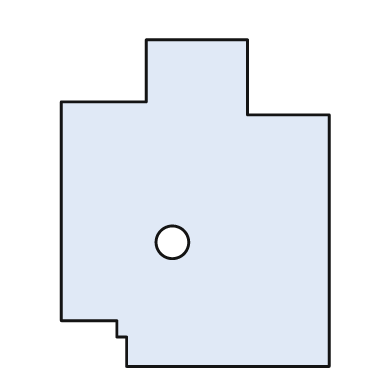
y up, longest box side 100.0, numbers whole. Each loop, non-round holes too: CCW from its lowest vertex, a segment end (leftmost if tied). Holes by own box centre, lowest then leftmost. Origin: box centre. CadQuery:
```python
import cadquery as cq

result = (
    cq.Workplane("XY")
    .moveTo(-21.0, -50.0)
    .lineTo(41.0, -50.0)
    .lineTo(41.0, 27.0)
    .lineTo(16.0, 27.0)
    .lineTo(16.0, 50.0)
    .lineTo(-15.0, 50.0)
    .lineTo(-15.0, 31.0)
    .lineTo(-41.0, 31.0)
    .lineTo(-41.0, -36.0)
    .lineTo(-24.0, -36.0)
    .lineTo(-24.0, -41.0)
    .lineTo(-21.0, -41.0)
    .close()
    .moveTo(-7.0, -12.0)
    .circle(5.0)
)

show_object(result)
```